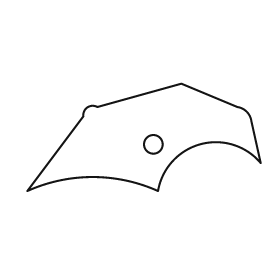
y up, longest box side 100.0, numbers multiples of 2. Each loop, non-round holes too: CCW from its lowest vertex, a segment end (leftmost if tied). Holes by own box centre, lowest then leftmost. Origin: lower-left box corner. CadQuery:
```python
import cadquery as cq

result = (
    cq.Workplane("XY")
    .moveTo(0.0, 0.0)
    .threePointArc((28.0, 6.0), (56.0, 0.0))
    .threePointArc((74.0, 20.0), (100.0, 12.0))
    .lineTo(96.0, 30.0)
    .threePointArc((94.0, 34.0), (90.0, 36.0))
    .lineTo(66.0, 46.0)
    .lineTo(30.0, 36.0)
    .threePointArc((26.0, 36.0), (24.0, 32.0))
    .close()
    .moveTo(54.0, 20.0)
    .circle(4.0)
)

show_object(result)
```